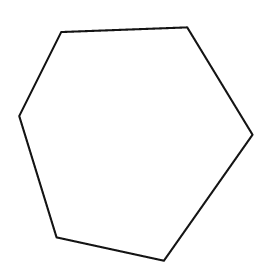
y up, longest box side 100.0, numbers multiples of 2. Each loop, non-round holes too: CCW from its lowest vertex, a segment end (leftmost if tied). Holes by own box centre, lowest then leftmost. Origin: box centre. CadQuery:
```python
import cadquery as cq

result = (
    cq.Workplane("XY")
    .moveTo(12.0, -50.0)
    .lineTo(50.0, 4.0)
    .lineTo(22.0, 50.0)
    .lineTo(-32.0, 48.0)
    .lineTo(-50.0, 12.0)
    .lineTo(-34.0, -40.0)
    .close()
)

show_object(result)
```